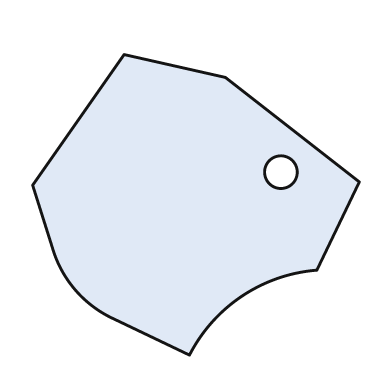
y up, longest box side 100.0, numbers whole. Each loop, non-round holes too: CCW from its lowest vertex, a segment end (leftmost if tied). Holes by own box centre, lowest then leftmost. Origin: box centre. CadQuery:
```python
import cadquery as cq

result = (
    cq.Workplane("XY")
    .moveTo(-2.0, -46.0)
    .threePointArc((14.0, -28.0), (37.0, -20.0))
    .lineTo(50.0, 7.0)
    .lineTo(9.0, 39.0)
    .lineTo(-22.0, 46.0)
    .lineTo(-50.0, 6.0)
    .lineTo(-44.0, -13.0)
    .threePointArc((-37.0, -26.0), (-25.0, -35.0))
    .close()
    .moveTo(26.0, 10.0)
    .circle(5.0)
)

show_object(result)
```